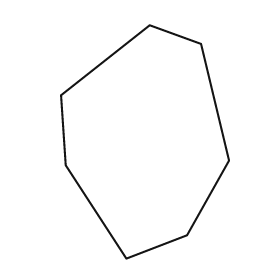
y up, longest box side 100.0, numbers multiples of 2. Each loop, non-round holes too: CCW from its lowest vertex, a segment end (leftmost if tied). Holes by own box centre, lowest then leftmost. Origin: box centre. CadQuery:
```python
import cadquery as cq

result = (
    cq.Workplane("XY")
    .moveTo(-8.0, -50.0)
    .lineTo(18.0, -40.0)
    .lineTo(36.0, -8.0)
    .lineTo(24.0, 42.0)
    .lineTo(2.0, 50.0)
    .lineTo(-36.0, 20.0)
    .lineTo(-34.0, -10.0)
    .close()
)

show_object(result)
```